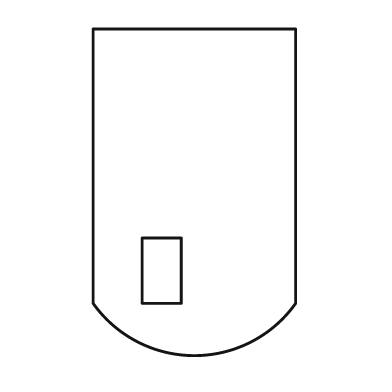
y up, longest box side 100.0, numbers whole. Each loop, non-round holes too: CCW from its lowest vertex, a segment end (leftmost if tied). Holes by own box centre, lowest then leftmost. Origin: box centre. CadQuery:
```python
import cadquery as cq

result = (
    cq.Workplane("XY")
    .moveTo(-31.0, -34.0)
    .threePointArc((0.0, -50.0), (31.0, -34.0))
    .lineTo(31.0, 50.0)
    .lineTo(-31.0, 50.0)
    .close()
    .moveTo(-16.0, -34.0)
    .lineTo(-4.0, -34.0)
    .lineTo(-4.0, -14.0)
    .lineTo(-16.0, -14.0)
    .close()
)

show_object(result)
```